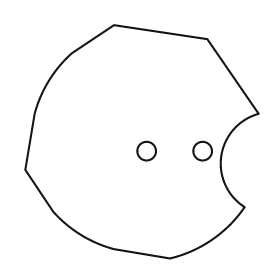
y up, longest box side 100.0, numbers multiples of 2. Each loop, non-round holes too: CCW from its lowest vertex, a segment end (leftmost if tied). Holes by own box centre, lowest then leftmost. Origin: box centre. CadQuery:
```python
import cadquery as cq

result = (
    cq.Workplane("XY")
    .moveTo(12.0, -50.0)
    .threePointArc((30.0, -42.0), (44.0, -28.0))
    .threePointArc((34.0, -6.0), (50.0, 12.0))
    .lineTo(28.0, 44.0)
    .lineTo(-12.0, 50.0)
    .lineTo(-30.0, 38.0)
    .threePointArc((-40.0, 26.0), (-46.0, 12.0))
    .lineTo(-50.0, -12.0)
    .lineTo(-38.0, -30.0)
    .threePointArc((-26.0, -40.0), (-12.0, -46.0))
    .close()
    .moveTo(2.0, -4.0)
    .circle(4.0)
    .moveTo(26.0, -4.0)
    .circle(4.0)
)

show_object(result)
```